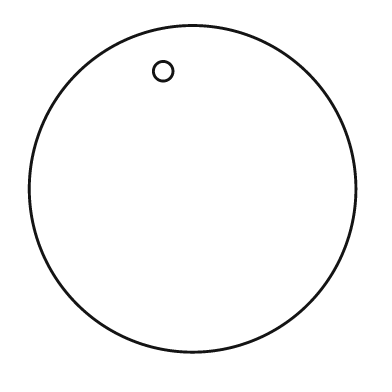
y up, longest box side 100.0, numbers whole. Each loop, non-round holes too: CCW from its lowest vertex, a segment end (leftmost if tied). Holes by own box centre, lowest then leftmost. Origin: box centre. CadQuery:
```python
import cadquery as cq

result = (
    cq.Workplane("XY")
    .moveTo(0.0, 0.0)
    .circle(50.0)
    .moveTo(-9.0, 36.0)
    .circle(3.0)
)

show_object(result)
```